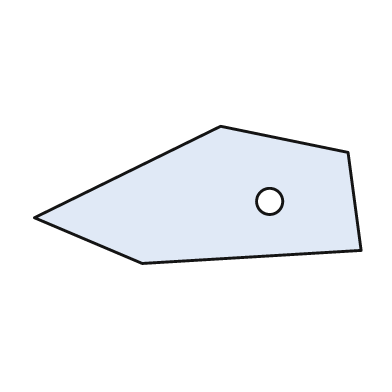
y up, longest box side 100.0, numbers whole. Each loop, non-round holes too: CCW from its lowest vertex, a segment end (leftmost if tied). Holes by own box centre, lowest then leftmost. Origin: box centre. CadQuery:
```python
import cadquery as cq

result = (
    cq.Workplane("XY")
    .moveTo(-17.0, -21.0)
    .lineTo(50.0, -17.0)
    .lineTo(46.0, 13.0)
    .lineTo(7.0, 21.0)
    .lineTo(-50.0, -7.0)
    .close()
    .moveTo(22.0, -2.0)
    .circle(4.0)
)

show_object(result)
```